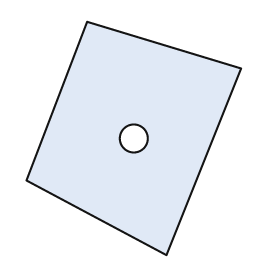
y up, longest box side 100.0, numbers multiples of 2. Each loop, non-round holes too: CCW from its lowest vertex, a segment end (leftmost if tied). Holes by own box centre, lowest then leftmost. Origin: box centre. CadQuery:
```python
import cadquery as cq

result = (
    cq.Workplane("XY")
    .moveTo(14.0, -50.0)
    .lineTo(46.0, 30.0)
    .lineTo(-20.0, 50.0)
    .lineTo(-46.0, -18.0)
    .close()
    .moveTo(0.0, 0.0)
    .circle(6.0)
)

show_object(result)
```